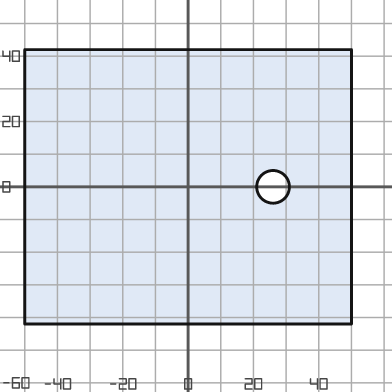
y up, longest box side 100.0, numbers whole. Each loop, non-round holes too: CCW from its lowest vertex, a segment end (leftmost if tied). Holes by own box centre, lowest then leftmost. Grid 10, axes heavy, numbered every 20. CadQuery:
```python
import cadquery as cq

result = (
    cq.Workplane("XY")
    .moveTo(-50.0, -42.0)
    .lineTo(50.0, -42.0)
    .lineTo(50.0, 42.0)
    .lineTo(-50.0, 42.0)
    .close()
    .moveTo(26.0, 0.0)
    .circle(5.0)
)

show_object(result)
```